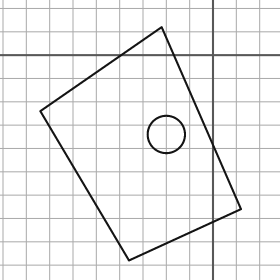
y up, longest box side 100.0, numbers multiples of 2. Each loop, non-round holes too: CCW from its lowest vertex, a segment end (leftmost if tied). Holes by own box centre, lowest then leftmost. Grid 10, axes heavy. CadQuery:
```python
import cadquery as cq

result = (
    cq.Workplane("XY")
    .moveTo(-36.0, -88.0)
    .lineTo(12.0, -66.0)
    .lineTo(-22.0, 12.0)
    .lineTo(-74.0, -24.0)
    .close()
    .moveTo(-20.0, -34.0)
    .circle(8.0)
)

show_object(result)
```